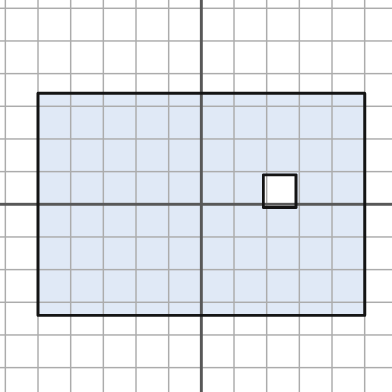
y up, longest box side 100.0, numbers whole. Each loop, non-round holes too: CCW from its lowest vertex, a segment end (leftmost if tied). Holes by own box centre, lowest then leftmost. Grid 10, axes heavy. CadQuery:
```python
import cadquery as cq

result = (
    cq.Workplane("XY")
    .moveTo(-50.0, -34.0)
    .lineTo(50.0, -34.0)
    .lineTo(50.0, 34.0)
    .lineTo(-50.0, 34.0)
    .close()
    .moveTo(19.0, -1.0)
    .lineTo(29.0, -1.0)
    .lineTo(29.0, 9.0)
    .lineTo(19.0, 9.0)
    .close()
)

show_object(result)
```